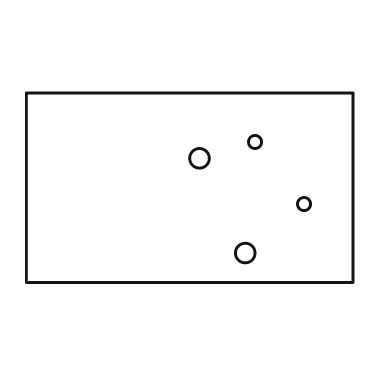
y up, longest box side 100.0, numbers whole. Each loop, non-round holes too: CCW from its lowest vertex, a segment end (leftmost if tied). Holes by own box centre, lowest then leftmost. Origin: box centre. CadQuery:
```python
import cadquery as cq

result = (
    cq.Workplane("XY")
    .moveTo(-50.0, -29.0)
    .lineTo(50.0, -29.0)
    .lineTo(50.0, 29.0)
    .lineTo(-50.0, 29.0)
    .close()
    .moveTo(17.0, -20.0)
    .circle(3.0)
    .moveTo(35.0, -5.0)
    .circle(2.0)
    .moveTo(3.0, 9.0)
    .circle(3.0)
    .moveTo(20.0, 14.0)
    .circle(2.0)
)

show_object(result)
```